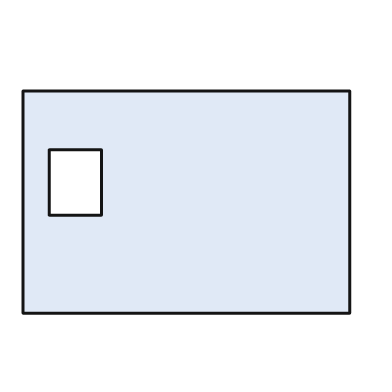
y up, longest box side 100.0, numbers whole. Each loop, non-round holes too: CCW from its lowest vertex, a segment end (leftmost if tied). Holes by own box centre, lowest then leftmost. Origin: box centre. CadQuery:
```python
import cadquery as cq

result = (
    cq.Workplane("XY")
    .moveTo(-50.0, -34.0)
    .lineTo(50.0, -34.0)
    .lineTo(50.0, 34.0)
    .lineTo(-50.0, 34.0)
    .close()
    .moveTo(-42.0, -4.0)
    .lineTo(-26.0, -4.0)
    .lineTo(-26.0, 16.0)
    .lineTo(-42.0, 16.0)
    .close()
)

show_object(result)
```